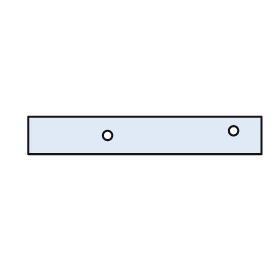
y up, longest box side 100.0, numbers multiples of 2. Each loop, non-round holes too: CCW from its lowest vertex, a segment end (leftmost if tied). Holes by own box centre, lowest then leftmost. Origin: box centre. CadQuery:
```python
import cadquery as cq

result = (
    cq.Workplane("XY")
    .moveTo(-50.0, -8.0)
    .lineTo(50.0, -8.0)
    .lineTo(50.0, 8.0)
    .lineTo(-50.0, 8.0)
    .close()
    .moveTo(-16.0, 0.0)
    .circle(2.0)
    .moveTo(38.0, 2.0)
    .circle(2.0)
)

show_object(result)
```